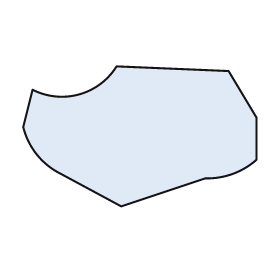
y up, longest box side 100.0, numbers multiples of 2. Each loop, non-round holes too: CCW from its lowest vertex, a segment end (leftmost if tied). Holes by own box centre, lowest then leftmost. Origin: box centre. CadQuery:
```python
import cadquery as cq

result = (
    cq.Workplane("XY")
    .moveTo(-8.0, -30.0)
    .lineTo(28.0, -18.0)
    .threePointArc((40.0, -16.0), (50.0, -10.0))
    .lineTo(50.0, 8.0)
    .lineTo(38.0, 28.0)
    .lineTo(-10.0, 30.0)
    .threePointArc((-26.0, 18.0), (-46.0, 20.0))
    .lineTo(-50.0, 4.0)
    .threePointArc((-44.0, -8.0), (-34.0, -16.0))
    .close()
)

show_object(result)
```